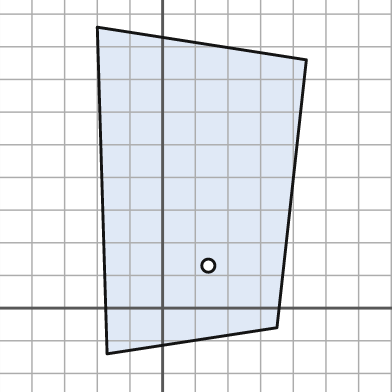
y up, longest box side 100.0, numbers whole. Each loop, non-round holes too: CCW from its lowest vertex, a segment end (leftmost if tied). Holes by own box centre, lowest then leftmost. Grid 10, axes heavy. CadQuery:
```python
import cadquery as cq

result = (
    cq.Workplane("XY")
    .moveTo(-17.0, -14.0)
    .lineTo(35.0, -6.0)
    .lineTo(44.0, 76.0)
    .lineTo(-20.0, 86.0)
    .close()
    .moveTo(14.0, 13.0)
    .circle(2.0)
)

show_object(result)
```